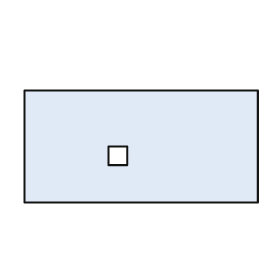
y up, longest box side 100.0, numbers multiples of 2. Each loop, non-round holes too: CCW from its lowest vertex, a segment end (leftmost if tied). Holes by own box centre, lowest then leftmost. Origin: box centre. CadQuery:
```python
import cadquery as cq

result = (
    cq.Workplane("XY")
    .moveTo(-50.0, -24.0)
    .lineTo(50.0, -24.0)
    .lineTo(50.0, 24.0)
    .lineTo(-50.0, 24.0)
    .close()
    .moveTo(-14.0, -8.0)
    .lineTo(-6.0, -8.0)
    .lineTo(-6.0, 0.0)
    .lineTo(-14.0, 0.0)
    .close()
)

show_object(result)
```